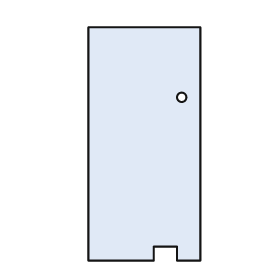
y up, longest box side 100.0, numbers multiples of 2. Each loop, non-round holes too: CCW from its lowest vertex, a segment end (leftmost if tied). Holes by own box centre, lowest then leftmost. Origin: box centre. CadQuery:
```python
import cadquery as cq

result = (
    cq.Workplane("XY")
    .moveTo(-24.0, -50.0)
    .lineTo(4.0, -50.0)
    .lineTo(4.0, -44.0)
    .lineTo(14.0, -44.0)
    .lineTo(14.0, -50.0)
    .lineTo(24.0, -50.0)
    .lineTo(24.0, 50.0)
    .lineTo(-24.0, 50.0)
    .close()
    .moveTo(16.0, 20.0)
    .circle(2.0)
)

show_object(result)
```